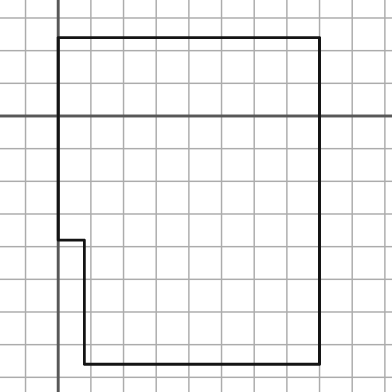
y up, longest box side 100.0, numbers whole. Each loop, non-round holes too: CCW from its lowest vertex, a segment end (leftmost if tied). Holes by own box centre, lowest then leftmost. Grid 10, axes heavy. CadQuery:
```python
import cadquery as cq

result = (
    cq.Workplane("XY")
    .moveTo(8.0, -76.0)
    .lineTo(80.0, -76.0)
    .lineTo(80.0, 24.0)
    .lineTo(0.0, 24.0)
    .lineTo(0.0, -38.0)
    .lineTo(8.0, -38.0)
    .close()
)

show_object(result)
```